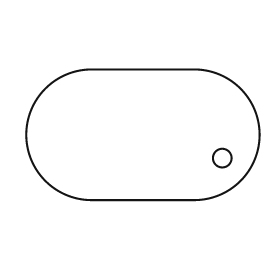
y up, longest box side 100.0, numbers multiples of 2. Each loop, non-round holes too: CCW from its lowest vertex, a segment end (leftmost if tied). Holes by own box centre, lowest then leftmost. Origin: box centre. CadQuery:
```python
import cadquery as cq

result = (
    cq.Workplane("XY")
    .moveTo(-22.0, -28.0)
    .lineTo(22.0, -28.0)
    .threePointArc((50.0, 0.0), (22.0, 28.0))
    .lineTo(-22.0, 28.0)
    .threePointArc((-50.0, 0.0), (-22.0, -28.0))
    .close()
    .moveTo(34.0, -10.0)
    .circle(4.0)
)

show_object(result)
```